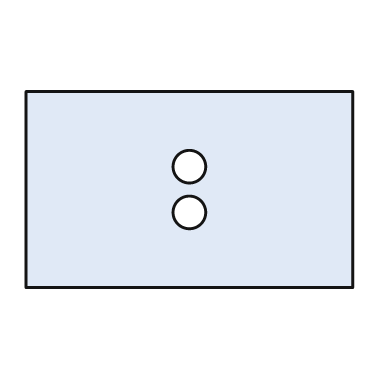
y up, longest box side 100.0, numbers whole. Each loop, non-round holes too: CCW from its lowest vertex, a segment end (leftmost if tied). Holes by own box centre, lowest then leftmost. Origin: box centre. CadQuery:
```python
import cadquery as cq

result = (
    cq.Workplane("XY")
    .moveTo(-50.0, -30.0)
    .lineTo(50.0, -30.0)
    .lineTo(50.0, 30.0)
    .lineTo(-50.0, 30.0)
    .close()
    .moveTo(0.0, -7.0)
    .circle(5.0)
    .moveTo(0.0, 7.0)
    .circle(5.0)
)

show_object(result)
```